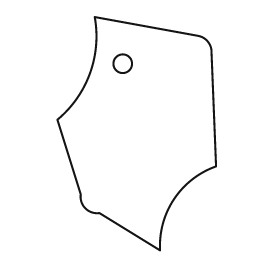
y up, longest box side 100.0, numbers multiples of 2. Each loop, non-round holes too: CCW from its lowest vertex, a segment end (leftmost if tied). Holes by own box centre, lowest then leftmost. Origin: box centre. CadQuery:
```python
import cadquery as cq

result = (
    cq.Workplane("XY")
    .moveTo(10.0, -50.0)
    .threePointArc((16.0, -28.0), (34.0, -14.0))
    .lineTo(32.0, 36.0)
    .threePointArc((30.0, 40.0), (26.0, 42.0))
    .lineTo(-18.0, 50.0)
    .threePointArc((-20.0, 26.0), (-34.0, 6.0))
    .lineTo(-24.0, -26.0)
    .threePointArc((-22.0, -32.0), (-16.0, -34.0))
    .close()
    .moveTo(-6.0, 30.0)
    .circle(4.0)
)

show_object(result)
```